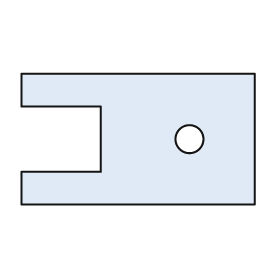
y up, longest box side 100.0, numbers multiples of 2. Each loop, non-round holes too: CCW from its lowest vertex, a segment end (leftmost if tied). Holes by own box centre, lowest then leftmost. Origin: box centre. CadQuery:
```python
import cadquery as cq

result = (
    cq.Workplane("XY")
    .moveTo(-50.0, -28.0)
    .lineTo(50.0, -28.0)
    .lineTo(50.0, 28.0)
    .lineTo(-50.0, 28.0)
    .lineTo(-50.0, 14.0)
    .lineTo(-16.0, 14.0)
    .lineTo(-16.0, -14.0)
    .lineTo(-50.0, -14.0)
    .close()
    .moveTo(22.0, 0.0)
    .circle(6.0)
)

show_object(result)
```